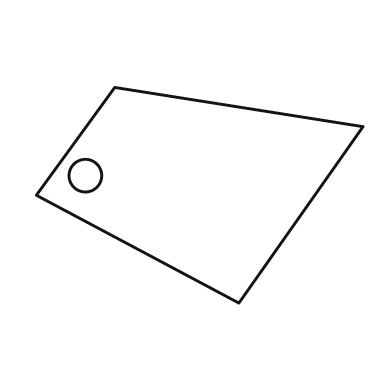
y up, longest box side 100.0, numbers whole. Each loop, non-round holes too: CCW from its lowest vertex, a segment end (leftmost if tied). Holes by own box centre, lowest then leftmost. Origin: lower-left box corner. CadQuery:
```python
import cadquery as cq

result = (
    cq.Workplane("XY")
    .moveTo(62.0, 0.0)
    .lineTo(100.0, 54.0)
    .lineTo(24.0, 66.0)
    .lineTo(0.0, 33.0)
    .close()
    .moveTo(15.0, 39.0)
    .circle(5.0)
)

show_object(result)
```